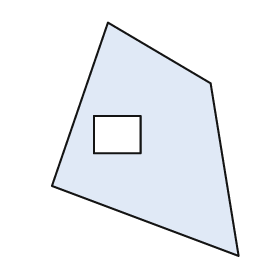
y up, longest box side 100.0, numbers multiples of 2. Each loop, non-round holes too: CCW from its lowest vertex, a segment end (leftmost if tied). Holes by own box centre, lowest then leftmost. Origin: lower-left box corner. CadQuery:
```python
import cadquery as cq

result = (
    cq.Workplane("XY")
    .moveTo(80.0, 0.0)
    .lineTo(68.0, 74.0)
    .lineTo(24.0, 100.0)
    .lineTo(0.0, 30.0)
    .close()
    .moveTo(18.0, 44.0)
    .lineTo(38.0, 44.0)
    .lineTo(38.0, 60.0)
    .lineTo(18.0, 60.0)
    .close()
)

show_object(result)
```